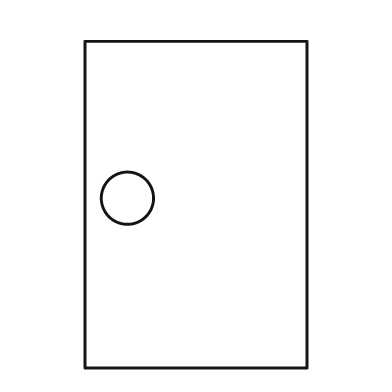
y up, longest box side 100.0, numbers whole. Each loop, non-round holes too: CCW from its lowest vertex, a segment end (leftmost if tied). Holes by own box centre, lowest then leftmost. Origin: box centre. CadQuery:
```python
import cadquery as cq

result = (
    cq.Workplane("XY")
    .moveTo(-34.0, -50.0)
    .lineTo(34.0, -50.0)
    .lineTo(34.0, 50.0)
    .lineTo(-34.0, 50.0)
    .close()
    .moveTo(-21.0, 2.0)
    .circle(8.0)
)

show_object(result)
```